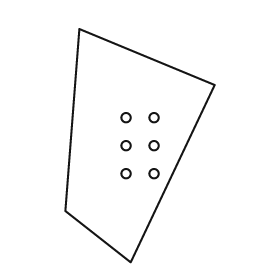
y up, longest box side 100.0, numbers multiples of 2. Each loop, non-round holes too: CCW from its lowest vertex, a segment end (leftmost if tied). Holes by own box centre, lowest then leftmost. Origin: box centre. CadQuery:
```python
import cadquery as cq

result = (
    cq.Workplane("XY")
    .moveTo(-4.0, -50.0)
    .lineTo(32.0, 26.0)
    .lineTo(-26.0, 50.0)
    .lineTo(-32.0, -28.0)
    .close()
    .moveTo(-6.0, -12.0)
    .circle(2.0)
    .moveTo(6.0, -12.0)
    .circle(2.0)
    .moveTo(-6.0, 0.0)
    .circle(2.0)
    .moveTo(6.0, 0.0)
    .circle(2.0)
    .moveTo(-6.0, 12.0)
    .circle(2.0)
    .moveTo(6.0, 12.0)
    .circle(2.0)
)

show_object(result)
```